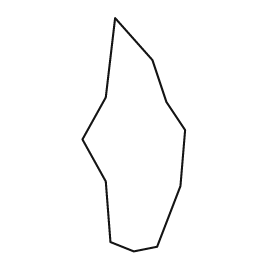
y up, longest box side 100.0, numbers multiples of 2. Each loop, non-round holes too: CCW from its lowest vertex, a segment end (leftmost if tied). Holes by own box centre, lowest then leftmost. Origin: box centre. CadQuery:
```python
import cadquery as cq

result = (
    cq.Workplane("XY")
    .moveTo(0.0, -50.0)
    .lineTo(10.0, -48.0)
    .lineTo(20.0, -22.0)
    .lineTo(22.0, 2.0)
    .lineTo(14.0, 14.0)
    .lineTo(8.0, 32.0)
    .lineTo(-8.0, 50.0)
    .lineTo(-12.0, 16.0)
    .lineTo(-22.0, -2.0)
    .lineTo(-12.0, -20.0)
    .lineTo(-10.0, -46.0)
    .close()
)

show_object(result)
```